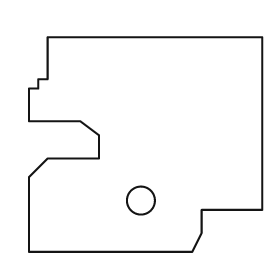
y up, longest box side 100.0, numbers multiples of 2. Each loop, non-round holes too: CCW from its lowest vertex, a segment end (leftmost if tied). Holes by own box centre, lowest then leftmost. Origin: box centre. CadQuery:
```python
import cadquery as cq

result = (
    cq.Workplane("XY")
    .moveTo(-50.0, -46.0)
    .lineTo(20.0, -46.0)
    .lineTo(24.0, -38.0)
    .lineTo(24.0, -28.0)
    .lineTo(50.0, -28.0)
    .lineTo(50.0, 46.0)
    .lineTo(-42.0, 46.0)
    .lineTo(-42.0, 28.0)
    .lineTo(-46.0, 28.0)
    .lineTo(-46.0, 24.0)
    .lineTo(-50.0, 24.0)
    .lineTo(-50.0, 10.0)
    .lineTo(-28.0, 10.0)
    .lineTo(-20.0, 4.0)
    .lineTo(-20.0, -6.0)
    .lineTo(-42.0, -6.0)
    .lineTo(-50.0, -14.0)
    .close()
    .moveTo(-2.0, -24.0)
    .circle(6.0)
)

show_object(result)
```